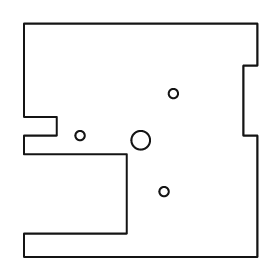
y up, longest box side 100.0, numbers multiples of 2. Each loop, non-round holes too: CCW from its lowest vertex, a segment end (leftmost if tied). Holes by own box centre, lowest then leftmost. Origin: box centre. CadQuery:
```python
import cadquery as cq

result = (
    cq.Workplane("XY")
    .moveTo(-50.0, -50.0)
    .lineTo(50.0, -50.0)
    .lineTo(50.0, 2.0)
    .lineTo(44.0, 2.0)
    .lineTo(44.0, 32.0)
    .lineTo(50.0, 32.0)
    .lineTo(50.0, 50.0)
    .lineTo(-50.0, 50.0)
    .lineTo(-50.0, 10.0)
    .lineTo(-36.0, 10.0)
    .lineTo(-36.0, 2.0)
    .lineTo(-50.0, 2.0)
    .lineTo(-50.0, -6.0)
    .lineTo(-6.0, -6.0)
    .lineTo(-6.0, -40.0)
    .lineTo(-50.0, -40.0)
    .close()
    .moveTo(10.0, -22.0)
    .circle(2.0)
    .moveTo(0.0, 0.0)
    .circle(4.0)
    .moveTo(-26.0, 2.0)
    .circle(2.0)
    .moveTo(14.0, 20.0)
    .circle(2.0)
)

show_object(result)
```